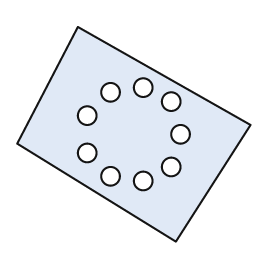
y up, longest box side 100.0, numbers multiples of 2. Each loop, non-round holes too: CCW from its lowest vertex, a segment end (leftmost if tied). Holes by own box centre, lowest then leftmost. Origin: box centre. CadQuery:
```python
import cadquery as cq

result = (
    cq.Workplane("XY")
    .moveTo(18.0, -46.0)
    .lineTo(50.0, 4.0)
    .lineTo(-24.0, 46.0)
    .lineTo(-50.0, -4.0)
    .close()
    .moveTo(4.0, -20.0)
    .circle(4.0)
    .moveTo(-10.0, -18.0)
    .circle(4.0)
    .moveTo(16.0, -14.0)
    .circle(4.0)
    .moveTo(-20.0, -8.0)
    .circle(4.0)
    .moveTo(20.0, 0.0)
    .circle(4.0)
    .moveTo(-20.0, 8.0)
    .circle(4.0)
    .moveTo(16.0, 14.0)
    .circle(4.0)
    .moveTo(-10.0, 18.0)
    .circle(4.0)
    .moveTo(4.0, 20.0)
    .circle(4.0)
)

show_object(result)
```